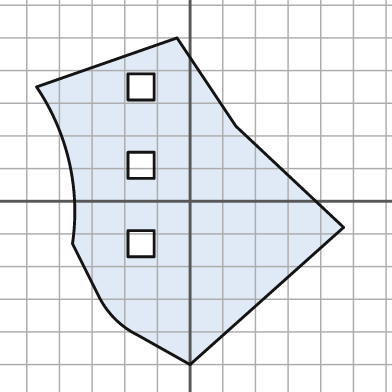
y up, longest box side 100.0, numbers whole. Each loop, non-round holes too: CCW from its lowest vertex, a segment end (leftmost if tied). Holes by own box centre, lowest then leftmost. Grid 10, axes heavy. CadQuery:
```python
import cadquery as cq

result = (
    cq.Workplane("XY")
    .moveTo(0.0, -50.0)
    .lineTo(47.0, -8.0)
    .lineTo(14.0, 23.0)
    .lineTo(-4.0, 50.0)
    .lineTo(-47.0, 35.0)
    .threePointArc((-37.0, 12.0), (-36.0, -13.0))
    .lineTo(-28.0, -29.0)
    .threePointArc((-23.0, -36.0), (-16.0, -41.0))
    .close()
    .moveTo(-19.0, -17.0)
    .lineTo(-11.0, -17.0)
    .lineTo(-11.0, -9.0)
    .lineTo(-19.0, -9.0)
    .close()
    .moveTo(-19.0, 7.0)
    .lineTo(-11.0, 7.0)
    .lineTo(-11.0, 15.0)
    .lineTo(-19.0, 15.0)
    .close()
    .moveTo(-19.0, 31.0)
    .lineTo(-11.0, 31.0)
    .lineTo(-11.0, 39.0)
    .lineTo(-19.0, 39.0)
    .close()
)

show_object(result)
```